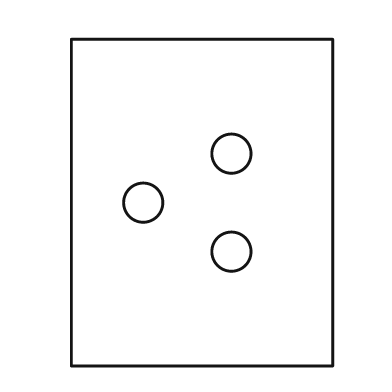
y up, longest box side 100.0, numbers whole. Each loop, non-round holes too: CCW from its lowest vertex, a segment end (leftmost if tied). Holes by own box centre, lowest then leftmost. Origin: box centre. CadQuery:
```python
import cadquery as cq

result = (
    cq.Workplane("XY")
    .moveTo(-40.0, -50.0)
    .lineTo(40.0, -50.0)
    .lineTo(40.0, 50.0)
    .lineTo(-40.0, 50.0)
    .close()
    .moveTo(9.0, -15.0)
    .circle(6.0)
    .moveTo(-18.0, 0.0)
    .circle(6.0)
    .moveTo(9.0, 15.0)
    .circle(6.0)
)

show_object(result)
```